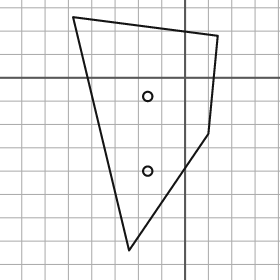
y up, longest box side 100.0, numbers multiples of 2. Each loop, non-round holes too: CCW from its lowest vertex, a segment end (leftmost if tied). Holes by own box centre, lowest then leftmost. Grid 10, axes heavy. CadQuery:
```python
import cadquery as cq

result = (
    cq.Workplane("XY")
    .moveTo(-24.0, -74.0)
    .lineTo(10.0, -24.0)
    .lineTo(14.0, 18.0)
    .lineTo(-48.0, 26.0)
    .close()
    .moveTo(-16.0, -40.0)
    .circle(2.0)
    .moveTo(-16.0, -8.0)
    .circle(2.0)
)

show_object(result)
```